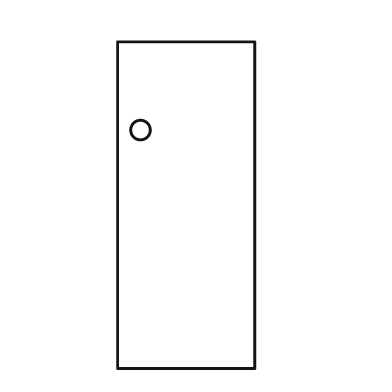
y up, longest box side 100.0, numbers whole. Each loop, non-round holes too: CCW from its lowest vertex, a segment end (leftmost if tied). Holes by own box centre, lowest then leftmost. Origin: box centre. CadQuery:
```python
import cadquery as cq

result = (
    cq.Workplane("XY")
    .moveTo(-21.0, -50.0)
    .lineTo(21.0, -50.0)
    .lineTo(21.0, 50.0)
    .lineTo(-21.0, 50.0)
    .close()
    .moveTo(-14.0, 23.0)
    .circle(3.0)
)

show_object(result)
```